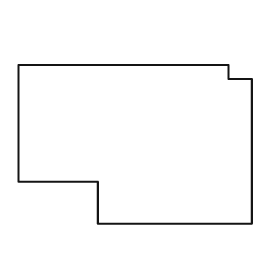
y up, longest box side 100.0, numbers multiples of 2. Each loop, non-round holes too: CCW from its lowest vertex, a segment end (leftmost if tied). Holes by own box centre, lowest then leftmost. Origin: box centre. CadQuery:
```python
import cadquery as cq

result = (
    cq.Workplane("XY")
    .moveTo(-16.0, -34.0)
    .lineTo(50.0, -34.0)
    .lineTo(50.0, 28.0)
    .lineTo(40.0, 28.0)
    .lineTo(40.0, 34.0)
    .lineTo(-50.0, 34.0)
    .lineTo(-50.0, -16.0)
    .lineTo(-16.0, -16.0)
    .close()
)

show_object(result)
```